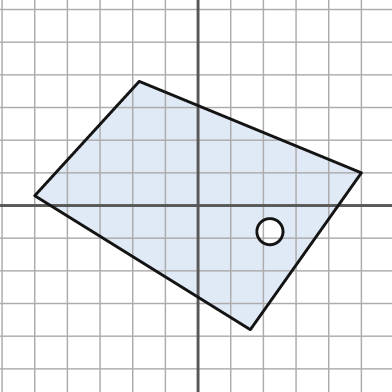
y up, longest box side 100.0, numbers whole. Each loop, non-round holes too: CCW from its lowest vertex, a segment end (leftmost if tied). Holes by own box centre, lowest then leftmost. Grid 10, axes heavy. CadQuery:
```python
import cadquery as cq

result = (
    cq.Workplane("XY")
    .moveTo(16.0, -38.0)
    .lineTo(50.0, 10.0)
    .lineTo(-18.0, 38.0)
    .lineTo(-50.0, 3.0)
    .close()
    .moveTo(22.0, -8.0)
    .circle(4.0)
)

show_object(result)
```